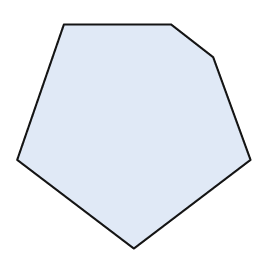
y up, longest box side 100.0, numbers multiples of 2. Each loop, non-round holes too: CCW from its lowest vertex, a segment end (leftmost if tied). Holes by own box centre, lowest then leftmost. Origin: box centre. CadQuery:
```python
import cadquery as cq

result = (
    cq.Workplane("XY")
    .moveTo(0.0, -48.0)
    .lineTo(50.0, -10.0)
    .lineTo(34.0, 34.0)
    .lineTo(16.0, 48.0)
    .lineTo(-30.0, 48.0)
    .lineTo(-50.0, -10.0)
    .close()
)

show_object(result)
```